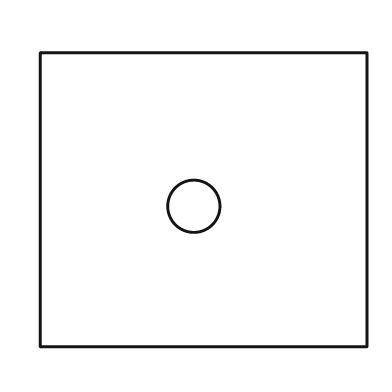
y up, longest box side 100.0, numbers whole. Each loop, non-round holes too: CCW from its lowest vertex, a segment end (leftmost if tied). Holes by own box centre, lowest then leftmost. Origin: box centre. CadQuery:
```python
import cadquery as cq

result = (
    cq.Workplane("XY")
    .moveTo(-50.0, -45.0)
    .lineTo(50.0, -45.0)
    .lineTo(50.0, 45.0)
    .lineTo(-50.0, 45.0)
    .close()
    .moveTo(-3.0, -2.0)
    .circle(8.0)
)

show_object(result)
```